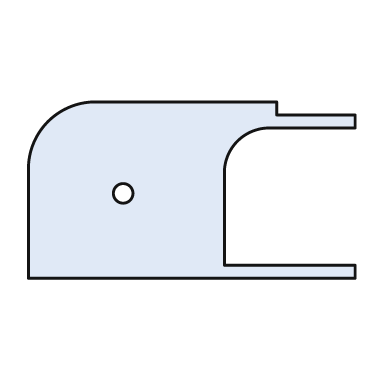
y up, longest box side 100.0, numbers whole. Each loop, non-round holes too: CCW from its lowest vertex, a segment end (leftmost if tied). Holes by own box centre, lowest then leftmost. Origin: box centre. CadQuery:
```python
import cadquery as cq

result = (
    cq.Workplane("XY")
    .moveTo(-50.0, -27.0)
    .lineTo(50.0, -27.0)
    .lineTo(50.0, -23.0)
    .lineTo(10.0, -23.0)
    .lineTo(10.0, 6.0)
    .threePointArc((14.0, 15.0), (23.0, 19.0))
    .lineTo(50.0, 19.0)
    .lineTo(50.0, 23.0)
    .lineTo(26.0, 23.0)
    .lineTo(26.0, 27.0)
    .lineTo(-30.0, 27.0)
    .threePointArc((-44.0, 21.0), (-50.0, 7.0))
    .close()
    .moveTo(-21.0, -1.0)
    .circle(3.0)
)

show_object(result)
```